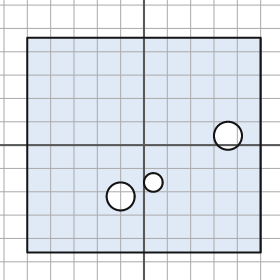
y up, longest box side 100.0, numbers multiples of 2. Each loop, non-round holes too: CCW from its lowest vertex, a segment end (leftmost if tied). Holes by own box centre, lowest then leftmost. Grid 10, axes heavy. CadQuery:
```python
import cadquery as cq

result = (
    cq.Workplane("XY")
    .moveTo(-50.0, -46.0)
    .lineTo(50.0, -46.0)
    .lineTo(50.0, 46.0)
    .lineTo(-50.0, 46.0)
    .close()
    .moveTo(-10.0, -22.0)
    .circle(6.0)
    .moveTo(4.0, -16.0)
    .circle(4.0)
    .moveTo(36.0, 4.0)
    .circle(6.0)
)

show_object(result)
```